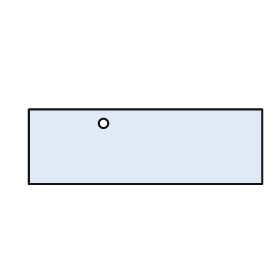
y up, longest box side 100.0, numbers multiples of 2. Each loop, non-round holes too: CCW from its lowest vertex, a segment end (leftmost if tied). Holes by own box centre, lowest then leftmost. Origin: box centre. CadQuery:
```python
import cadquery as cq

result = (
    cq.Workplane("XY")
    .moveTo(-50.0, -16.0)
    .lineTo(50.0, -16.0)
    .lineTo(50.0, 16.0)
    .lineTo(-50.0, 16.0)
    .close()
    .moveTo(-18.0, 10.0)
    .circle(2.0)
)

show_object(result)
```